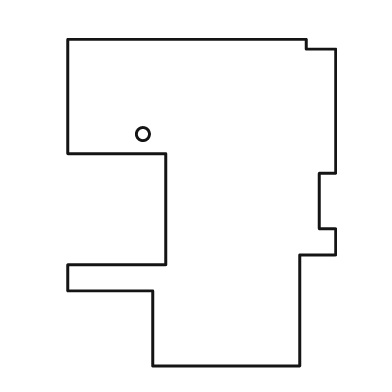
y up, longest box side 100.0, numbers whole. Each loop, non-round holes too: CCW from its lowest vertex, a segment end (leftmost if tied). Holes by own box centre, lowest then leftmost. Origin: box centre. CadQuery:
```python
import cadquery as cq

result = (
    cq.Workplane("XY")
    .moveTo(-15.0, -50.0)
    .lineTo(30.0, -50.0)
    .lineTo(30.0, -16.0)
    .lineTo(41.0, -16.0)
    .lineTo(41.0, -8.0)
    .lineTo(36.0, -8.0)
    .lineTo(36.0, 9.0)
    .lineTo(41.0, 9.0)
    .lineTo(41.0, 47.0)
    .lineTo(32.0, 47.0)
    .lineTo(32.0, 50.0)
    .lineTo(-41.0, 50.0)
    .lineTo(-41.0, 15.0)
    .lineTo(-11.0, 15.0)
    .lineTo(-11.0, -19.0)
    .lineTo(-41.0, -19.0)
    .lineTo(-41.0, -27.0)
    .lineTo(-15.0, -27.0)
    .close()
    .moveTo(-18.0, 21.0)
    .circle(2.0)
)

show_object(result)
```